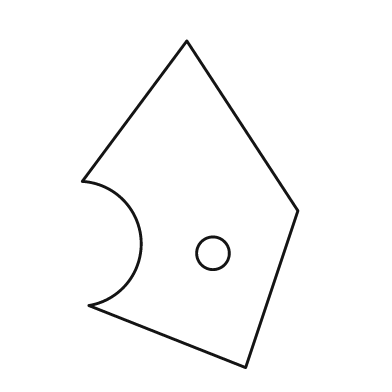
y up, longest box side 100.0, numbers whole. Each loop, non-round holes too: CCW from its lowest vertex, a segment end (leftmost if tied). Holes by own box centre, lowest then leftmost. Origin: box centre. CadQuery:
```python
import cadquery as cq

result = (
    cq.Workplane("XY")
    .moveTo(17.0, -50.0)
    .lineTo(33.0, -2.0)
    .lineTo(-1.0, 50.0)
    .lineTo(-33.0, 7.0)
    .threePointArc((-15.0, -11.0), (-31.0, -31.0))
    .close()
    .moveTo(7.0, -15.0)
    .circle(5.0)
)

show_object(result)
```